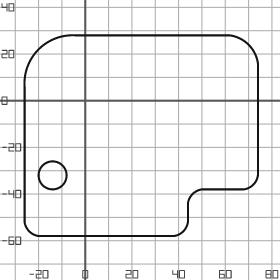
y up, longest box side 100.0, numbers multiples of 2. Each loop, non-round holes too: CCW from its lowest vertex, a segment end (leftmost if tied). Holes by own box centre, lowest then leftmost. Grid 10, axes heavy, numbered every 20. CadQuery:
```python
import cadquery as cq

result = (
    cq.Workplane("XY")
    .moveTo(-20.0, -58.0)
    .lineTo(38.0, -58.0)
    .threePointArc((42.0, -56.0), (44.0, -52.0))
    .lineTo(44.0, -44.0)
    .threePointArc((46.0, -40.0), (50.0, -38.0))
    .lineTo(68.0, -38.0)
    .threePointArc((72.0, -36.0), (74.0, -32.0))
    .lineTo(74.0, 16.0)
    .threePointArc((70.0, 24.0), (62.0, 28.0))
    .lineTo(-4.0, 28.0)
    .threePointArc((-20.0, 22.0), (-26.0, 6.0))
    .lineTo(-26.0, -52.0)
    .threePointArc((-24.0, -56.0), (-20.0, -58.0))
    .close()
    .moveTo(-14.0, -32.0)
    .circle(6.0)
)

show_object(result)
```